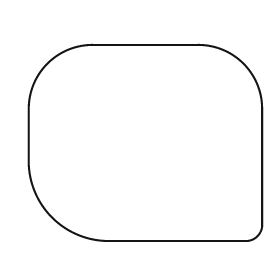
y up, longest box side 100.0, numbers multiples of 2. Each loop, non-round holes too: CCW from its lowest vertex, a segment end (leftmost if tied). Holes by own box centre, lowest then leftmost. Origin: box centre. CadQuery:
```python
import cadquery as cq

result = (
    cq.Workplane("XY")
    .moveTo(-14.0, -42.0)
    .lineTo(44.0, -42.0)
    .threePointArc((48.0, -40.0), (50.0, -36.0))
    .lineTo(50.0, 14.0)
    .threePointArc((42.0, 34.0), (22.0, 42.0))
    .lineTo(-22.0, 42.0)
    .threePointArc((-42.0, 34.0), (-50.0, 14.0))
    .lineTo(-50.0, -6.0)
    .threePointArc((-40.0, -32.0), (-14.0, -42.0))
    .close()
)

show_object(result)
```